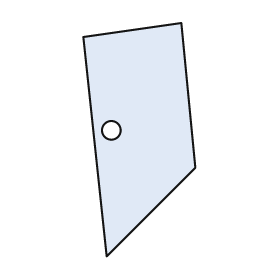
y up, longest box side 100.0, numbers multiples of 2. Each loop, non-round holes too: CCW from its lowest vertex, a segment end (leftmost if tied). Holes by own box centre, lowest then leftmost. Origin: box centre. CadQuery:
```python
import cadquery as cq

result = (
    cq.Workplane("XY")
    .moveTo(-14.0, -50.0)
    .lineTo(24.0, -12.0)
    .lineTo(18.0, 50.0)
    .lineTo(-24.0, 44.0)
    .close()
    .moveTo(-12.0, 4.0)
    .circle(4.0)
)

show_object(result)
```